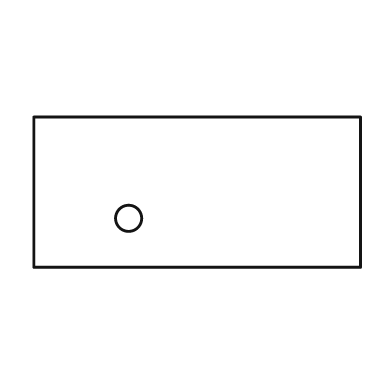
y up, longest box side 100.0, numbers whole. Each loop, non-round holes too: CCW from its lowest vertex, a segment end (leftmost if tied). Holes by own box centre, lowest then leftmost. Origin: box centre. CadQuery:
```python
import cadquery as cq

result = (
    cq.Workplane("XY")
    .moveTo(-50.0, -23.0)
    .lineTo(50.0, -23.0)
    .lineTo(50.0, 23.0)
    .lineTo(-50.0, 23.0)
    .close()
    .moveTo(-21.0, -8.0)
    .circle(4.0)
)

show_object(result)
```